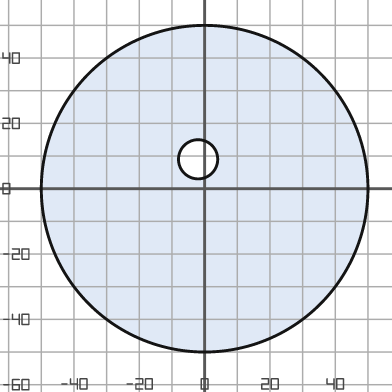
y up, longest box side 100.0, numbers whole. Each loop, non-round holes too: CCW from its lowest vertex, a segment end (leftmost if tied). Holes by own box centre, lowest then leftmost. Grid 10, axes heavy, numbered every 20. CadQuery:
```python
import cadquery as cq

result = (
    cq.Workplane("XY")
    .moveTo(0.0, 0.0)
    .circle(50.0)
    .moveTo(-2.0, 9.0)
    .circle(6.0)
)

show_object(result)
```